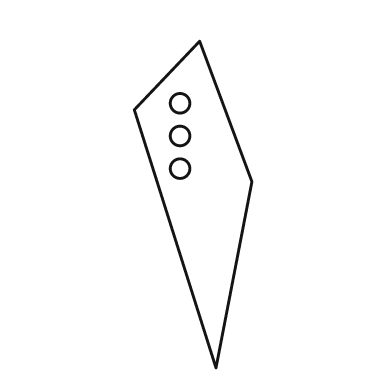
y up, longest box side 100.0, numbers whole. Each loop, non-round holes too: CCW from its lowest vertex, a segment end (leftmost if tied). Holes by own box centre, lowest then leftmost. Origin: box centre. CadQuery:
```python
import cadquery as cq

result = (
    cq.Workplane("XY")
    .moveTo(7.0, -50.0)
    .lineTo(18.0, 7.0)
    .lineTo(2.0, 50.0)
    .lineTo(-18.0, 29.0)
    .close()
    .moveTo(-4.0, 11.0)
    .circle(3.0)
    .moveTo(-4.0, 21.0)
    .circle(3.0)
    .moveTo(-4.0, 31.0)
    .circle(3.0)
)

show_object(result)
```